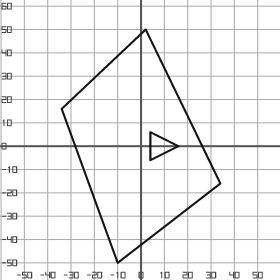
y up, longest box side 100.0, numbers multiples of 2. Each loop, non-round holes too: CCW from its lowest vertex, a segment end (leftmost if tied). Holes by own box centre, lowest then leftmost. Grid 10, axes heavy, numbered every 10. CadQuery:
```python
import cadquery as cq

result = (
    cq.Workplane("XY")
    .moveTo(-10.0, -50.0)
    .lineTo(34.0, -16.0)
    .lineTo(2.0, 50.0)
    .lineTo(-34.0, 16.0)
    .close()
    .moveTo(4.0, -6.0)
    .lineTo(16.0, 0.0)
    .lineTo(4.0, 6.0)
    .close()
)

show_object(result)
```